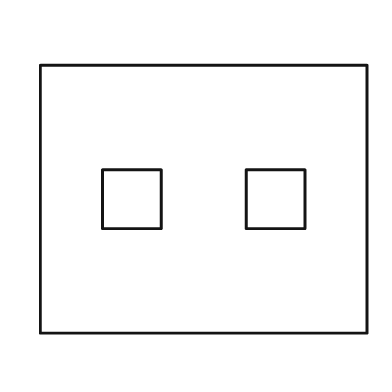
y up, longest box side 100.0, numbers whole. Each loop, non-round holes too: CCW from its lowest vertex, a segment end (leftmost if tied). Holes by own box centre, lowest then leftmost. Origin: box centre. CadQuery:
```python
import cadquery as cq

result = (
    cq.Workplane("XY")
    .moveTo(-50.0, -41.0)
    .lineTo(50.0, -41.0)
    .lineTo(50.0, 41.0)
    .lineTo(-50.0, 41.0)
    .close()
    .moveTo(-31.0, -9.0)
    .lineTo(-13.0, -9.0)
    .lineTo(-13.0, 9.0)
    .lineTo(-31.0, 9.0)
    .close()
    .moveTo(13.0, -9.0)
    .lineTo(31.0, -9.0)
    .lineTo(31.0, 9.0)
    .lineTo(13.0, 9.0)
    .close()
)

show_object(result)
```